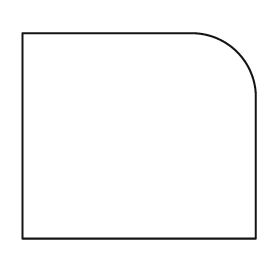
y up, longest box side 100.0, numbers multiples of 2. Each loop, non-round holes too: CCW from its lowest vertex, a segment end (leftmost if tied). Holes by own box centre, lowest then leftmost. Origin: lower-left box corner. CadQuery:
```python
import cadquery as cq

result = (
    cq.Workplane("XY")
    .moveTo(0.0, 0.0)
    .lineTo(100.0, 0.0)
    .lineTo(100.0, 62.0)
    .threePointArc((92.0, 80.0), (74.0, 88.0))
    .lineTo(0.0, 88.0)
    .close()
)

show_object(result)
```